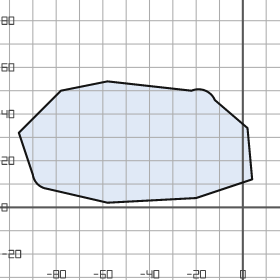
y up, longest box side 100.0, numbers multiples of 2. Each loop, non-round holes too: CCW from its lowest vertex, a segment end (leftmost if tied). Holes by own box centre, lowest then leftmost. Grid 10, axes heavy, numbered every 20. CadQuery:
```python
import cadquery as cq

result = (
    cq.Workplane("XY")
    .moveTo(-58.0, 2.0)
    .lineTo(-20.0, 4.0)
    .lineTo(4.0, 12.0)
    .lineTo(2.0, 34.0)
    .lineTo(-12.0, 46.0)
    .threePointArc((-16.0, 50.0), (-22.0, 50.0))
    .lineTo(-58.0, 54.0)
    .lineTo(-78.0, 50.0)
    .lineTo(-96.0, 32.0)
    .lineTo(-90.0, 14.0)
    .threePointArc((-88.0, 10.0), (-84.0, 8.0))
    .close()
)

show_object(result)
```